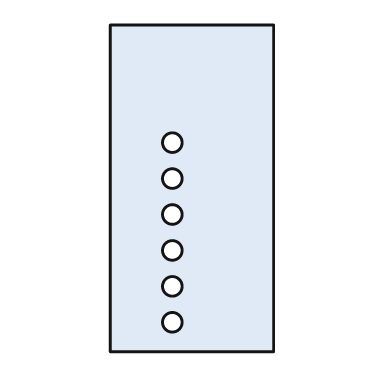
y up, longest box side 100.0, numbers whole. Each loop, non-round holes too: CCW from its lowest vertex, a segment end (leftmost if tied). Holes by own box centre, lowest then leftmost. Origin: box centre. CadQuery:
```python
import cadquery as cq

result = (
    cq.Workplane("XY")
    .moveTo(-25.0, -50.0)
    .lineTo(25.0, -50.0)
    .lineTo(25.0, 50.0)
    .lineTo(-25.0, 50.0)
    .close()
    .moveTo(-6.0, -41.0)
    .circle(3.0)
    .moveTo(-6.0, -30.0)
    .circle(3.0)
    .moveTo(-6.0, -19.0)
    .circle(3.0)
    .moveTo(-6.0, -8.0)
    .circle(3.0)
    .moveTo(-6.0, 3.0)
    .circle(3.0)
    .moveTo(-6.0, 14.0)
    .circle(3.0)
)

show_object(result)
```